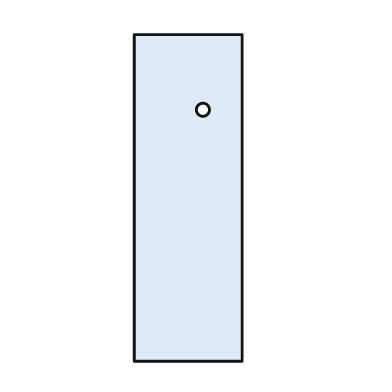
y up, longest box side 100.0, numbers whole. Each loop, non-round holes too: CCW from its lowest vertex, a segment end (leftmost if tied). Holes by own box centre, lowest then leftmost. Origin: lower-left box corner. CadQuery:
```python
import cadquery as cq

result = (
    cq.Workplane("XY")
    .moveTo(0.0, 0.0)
    .lineTo(33.0, 0.0)
    .lineTo(33.0, 100.0)
    .lineTo(0.0, 100.0)
    .close()
    .moveTo(21.0, 77.0)
    .circle(2.0)
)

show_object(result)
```